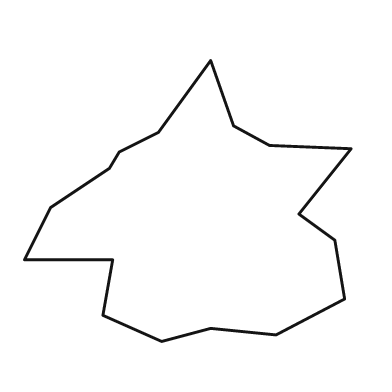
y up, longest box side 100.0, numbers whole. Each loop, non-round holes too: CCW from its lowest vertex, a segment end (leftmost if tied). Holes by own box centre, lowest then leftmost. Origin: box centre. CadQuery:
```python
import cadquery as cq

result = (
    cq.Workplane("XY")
    .moveTo(-8.0, -43.0)
    .lineTo(7.0, -39.0)
    .lineTo(27.0, -41.0)
    .lineTo(48.0, -30.0)
    .lineTo(45.0, -12.0)
    .lineTo(34.0, -4.0)
    .lineTo(50.0, 16.0)
    .lineTo(25.0, 17.0)
    .lineTo(14.0, 23.0)
    .lineTo(7.0, 43.0)
    .lineTo(-9.0, 21.0)
    .lineTo(-21.0, 15.0)
    .lineTo(-24.0, 10.0)
    .lineTo(-42.0, -2.0)
    .lineTo(-50.0, -18.0)
    .lineTo(-23.0, -18.0)
    .lineTo(-26.0, -35.0)
    .close()
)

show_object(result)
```